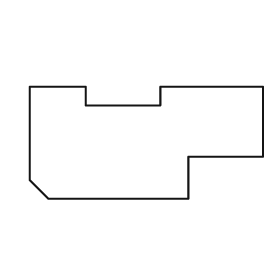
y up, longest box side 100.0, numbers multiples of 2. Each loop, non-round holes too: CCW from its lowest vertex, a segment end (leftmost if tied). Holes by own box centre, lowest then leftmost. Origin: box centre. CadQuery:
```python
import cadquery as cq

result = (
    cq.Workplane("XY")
    .moveTo(-42.0, -24.0)
    .lineTo(18.0, -24.0)
    .lineTo(18.0, -6.0)
    .lineTo(50.0, -6.0)
    .lineTo(50.0, 24.0)
    .lineTo(6.0, 24.0)
    .lineTo(6.0, 16.0)
    .lineTo(-26.0, 16.0)
    .lineTo(-26.0, 24.0)
    .lineTo(-50.0, 24.0)
    .lineTo(-50.0, -16.0)
    .close()
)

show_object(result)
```